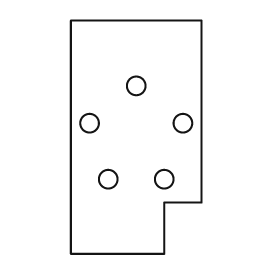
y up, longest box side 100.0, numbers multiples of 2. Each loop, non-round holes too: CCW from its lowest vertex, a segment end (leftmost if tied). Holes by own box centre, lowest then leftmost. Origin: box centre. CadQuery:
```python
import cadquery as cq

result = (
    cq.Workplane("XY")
    .moveTo(-28.0, -50.0)
    .lineTo(12.0, -50.0)
    .lineTo(12.0, -28.0)
    .lineTo(28.0, -28.0)
    .lineTo(28.0, 50.0)
    .lineTo(-28.0, 50.0)
    .close()
    .moveTo(-12.0, -18.0)
    .circle(4.0)
    .moveTo(12.0, -18.0)
    .circle(4.0)
    .moveTo(-20.0, 6.0)
    .circle(4.0)
    .moveTo(20.0, 6.0)
    .circle(4.0)
    .moveTo(0.0, 22.0)
    .circle(4.0)
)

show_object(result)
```